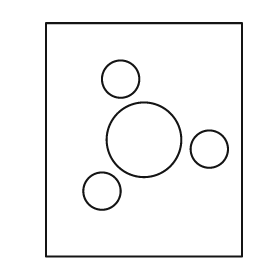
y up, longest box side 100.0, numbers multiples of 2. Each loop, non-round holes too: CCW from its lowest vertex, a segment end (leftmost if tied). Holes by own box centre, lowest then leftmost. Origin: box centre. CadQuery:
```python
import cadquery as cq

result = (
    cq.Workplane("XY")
    .moveTo(-42.0, -50.0)
    .lineTo(42.0, -50.0)
    .lineTo(42.0, 50.0)
    .lineTo(-42.0, 50.0)
    .close()
    .moveTo(-18.0, -22.0)
    .circle(8.0)
    .moveTo(28.0, -4.0)
    .circle(8.0)
    .moveTo(0.0, 0.0)
    .circle(16.0)
    .moveTo(-10.0, 26.0)
    .circle(8.0)
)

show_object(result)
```